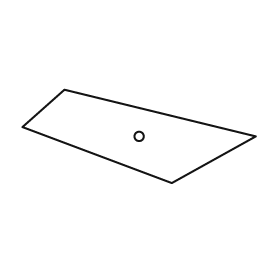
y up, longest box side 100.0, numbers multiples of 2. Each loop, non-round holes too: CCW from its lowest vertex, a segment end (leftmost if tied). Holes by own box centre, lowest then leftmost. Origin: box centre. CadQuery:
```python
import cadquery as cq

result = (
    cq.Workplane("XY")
    .moveTo(14.0, -20.0)
    .lineTo(50.0, 0.0)
    .lineTo(-32.0, 20.0)
    .lineTo(-50.0, 4.0)
    .close()
    .moveTo(0.0, 0.0)
    .circle(2.0)
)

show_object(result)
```